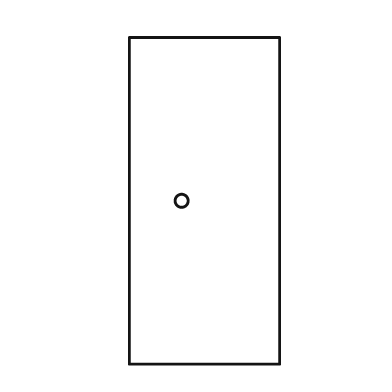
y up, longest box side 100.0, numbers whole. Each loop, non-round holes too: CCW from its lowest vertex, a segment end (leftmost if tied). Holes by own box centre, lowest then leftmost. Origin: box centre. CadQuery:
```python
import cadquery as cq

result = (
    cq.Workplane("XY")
    .moveTo(-23.0, -50.0)
    .lineTo(23.0, -50.0)
    .lineTo(23.0, 50.0)
    .lineTo(-23.0, 50.0)
    .close()
    .moveTo(-7.0, 0.0)
    .circle(2.0)
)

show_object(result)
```